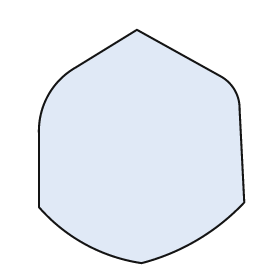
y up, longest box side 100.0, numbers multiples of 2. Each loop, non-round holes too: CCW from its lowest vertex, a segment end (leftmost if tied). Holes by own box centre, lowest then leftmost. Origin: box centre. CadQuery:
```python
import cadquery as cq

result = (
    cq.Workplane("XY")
    .moveTo(0.0, -50.0)
    .threePointArc((24.0, -40.0), (44.0, -24.0))
    .lineTo(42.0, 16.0)
    .threePointArc((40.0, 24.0), (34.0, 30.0))
    .lineTo(-2.0, 50.0)
    .lineTo(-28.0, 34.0)
    .threePointArc((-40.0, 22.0), (-44.0, 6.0))
    .lineTo(-44.0, -26.0)
    .threePointArc((-24.0, -42.0), (0.0, -50.0))
    .close()
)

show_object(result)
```